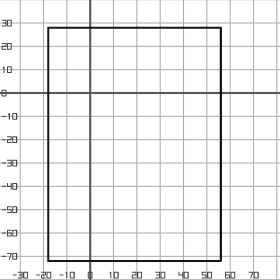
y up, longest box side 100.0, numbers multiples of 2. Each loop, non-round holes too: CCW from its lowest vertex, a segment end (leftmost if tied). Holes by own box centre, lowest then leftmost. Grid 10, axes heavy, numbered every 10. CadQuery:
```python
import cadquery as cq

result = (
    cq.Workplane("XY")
    .moveTo(-18.0, -72.0)
    .lineTo(56.0, -72.0)
    .lineTo(56.0, 28.0)
    .lineTo(-18.0, 28.0)
    .close()
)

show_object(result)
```